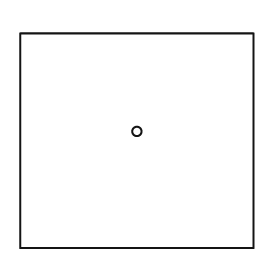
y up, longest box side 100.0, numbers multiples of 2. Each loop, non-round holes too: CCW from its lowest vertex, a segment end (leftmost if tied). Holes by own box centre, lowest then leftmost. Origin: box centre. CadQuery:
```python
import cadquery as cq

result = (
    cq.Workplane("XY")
    .moveTo(-50.0, -46.0)
    .lineTo(50.0, -46.0)
    .lineTo(50.0, 46.0)
    .lineTo(-50.0, 46.0)
    .close()
    .moveTo(0.0, 4.0)
    .circle(2.0)
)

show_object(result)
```